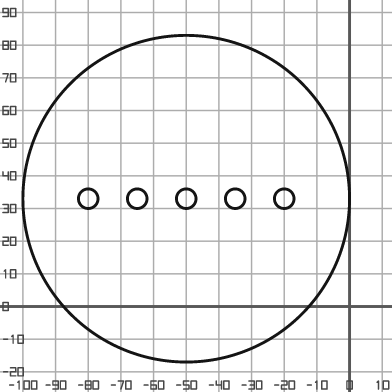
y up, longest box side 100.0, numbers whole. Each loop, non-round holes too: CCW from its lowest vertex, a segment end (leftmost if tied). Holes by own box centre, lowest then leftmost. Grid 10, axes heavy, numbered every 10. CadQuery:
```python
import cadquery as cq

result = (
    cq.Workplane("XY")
    .moveTo(-50.0, 33.0)
    .circle(50.0)
    .moveTo(-80.0, 33.0)
    .circle(3.0)
    .moveTo(-65.0, 33.0)
    .circle(3.0)
    .moveTo(-50.0, 33.0)
    .circle(3.0)
    .moveTo(-35.0, 33.0)
    .circle(3.0)
    .moveTo(-20.0, 33.0)
    .circle(3.0)
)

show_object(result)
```